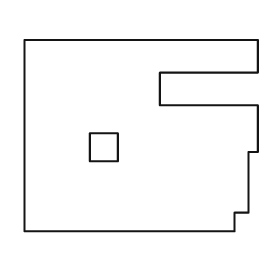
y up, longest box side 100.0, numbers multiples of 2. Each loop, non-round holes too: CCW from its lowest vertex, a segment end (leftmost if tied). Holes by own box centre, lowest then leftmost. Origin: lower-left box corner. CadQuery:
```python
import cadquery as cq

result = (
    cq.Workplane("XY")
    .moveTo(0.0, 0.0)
    .lineTo(90.0, 0.0)
    .lineTo(90.0, 8.0)
    .lineTo(96.0, 8.0)
    .lineTo(96.0, 34.0)
    .lineTo(100.0, 34.0)
    .lineTo(100.0, 54.0)
    .lineTo(58.0, 54.0)
    .lineTo(58.0, 68.0)
    .lineTo(100.0, 68.0)
    .lineTo(100.0, 82.0)
    .lineTo(0.0, 82.0)
    .close()
    .moveTo(28.0, 30.0)
    .lineTo(40.0, 30.0)
    .lineTo(40.0, 42.0)
    .lineTo(28.0, 42.0)
    .close()
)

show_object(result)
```